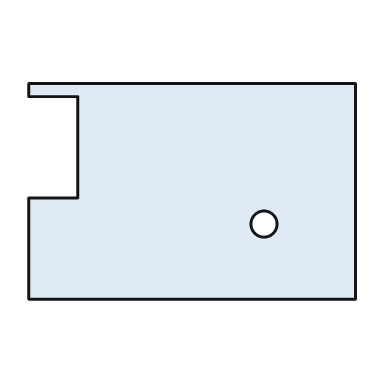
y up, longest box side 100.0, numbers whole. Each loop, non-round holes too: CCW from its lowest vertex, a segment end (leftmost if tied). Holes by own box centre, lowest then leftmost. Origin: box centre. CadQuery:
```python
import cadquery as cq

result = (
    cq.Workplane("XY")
    .moveTo(-50.0, -33.0)
    .lineTo(50.0, -33.0)
    .lineTo(50.0, 33.0)
    .lineTo(-50.0, 33.0)
    .lineTo(-50.0, 29.0)
    .lineTo(-35.0, 29.0)
    .lineTo(-35.0, -2.0)
    .lineTo(-50.0, -2.0)
    .close()
    .moveTo(22.0, -10.0)
    .circle(4.0)
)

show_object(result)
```